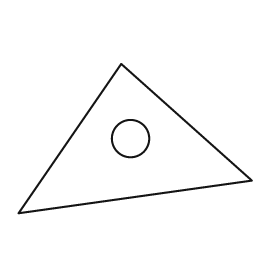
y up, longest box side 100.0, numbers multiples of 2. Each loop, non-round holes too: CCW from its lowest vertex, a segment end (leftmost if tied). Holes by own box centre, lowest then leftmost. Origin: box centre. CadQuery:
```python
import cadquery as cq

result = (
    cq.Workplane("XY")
    .moveTo(-50.0, -32.0)
    .lineTo(50.0, -18.0)
    .lineTo(-6.0, 32.0)
    .close()
    .moveTo(-2.0, 0.0)
    .circle(8.0)
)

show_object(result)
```